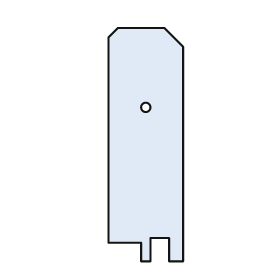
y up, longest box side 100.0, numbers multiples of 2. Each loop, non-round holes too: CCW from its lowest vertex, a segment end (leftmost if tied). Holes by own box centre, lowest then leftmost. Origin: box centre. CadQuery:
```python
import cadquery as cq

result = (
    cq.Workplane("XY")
    .moveTo(-2.0, -50.0)
    .lineTo(2.0, -50.0)
    .lineTo(2.0, -40.0)
    .lineTo(10.0, -40.0)
    .lineTo(10.0, -50.0)
    .lineTo(16.0, -50.0)
    .lineTo(16.0, 42.0)
    .lineTo(8.0, 50.0)
    .lineTo(-12.0, 50.0)
    .lineTo(-16.0, 46.0)
    .lineTo(-16.0, -42.0)
    .lineTo(-2.0, -42.0)
    .close()
    .moveTo(0.0, 16.0)
    .circle(2.0)
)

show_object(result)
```